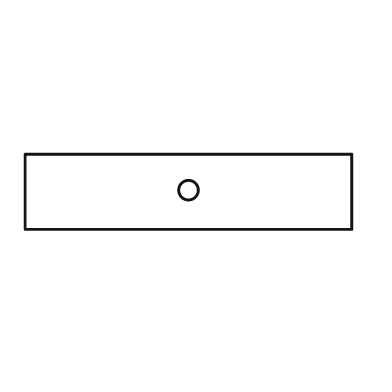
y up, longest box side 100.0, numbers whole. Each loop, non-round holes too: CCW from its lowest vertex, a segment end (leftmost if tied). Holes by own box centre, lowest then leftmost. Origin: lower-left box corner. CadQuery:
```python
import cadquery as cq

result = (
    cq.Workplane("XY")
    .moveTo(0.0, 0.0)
    .lineTo(100.0, 0.0)
    .lineTo(100.0, 23.0)
    .lineTo(0.0, 23.0)
    .close()
    .moveTo(50.0, 12.0)
    .circle(3.0)
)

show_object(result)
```